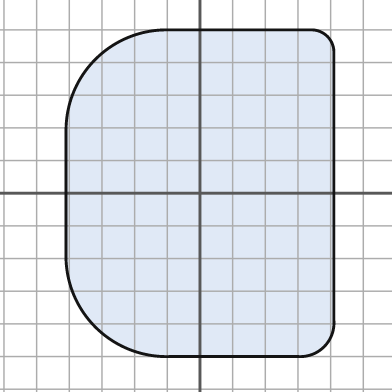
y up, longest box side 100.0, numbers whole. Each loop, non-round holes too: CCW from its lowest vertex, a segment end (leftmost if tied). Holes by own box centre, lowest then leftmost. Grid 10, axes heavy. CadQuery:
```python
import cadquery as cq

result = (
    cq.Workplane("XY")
    .moveTo(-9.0, -50.0)
    .lineTo(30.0, -50.0)
    .threePointArc((38.0, -47.0), (41.0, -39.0))
    .lineTo(41.0, 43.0)
    .threePointArc((39.0, 48.0), (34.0, 50.0))
    .lineTo(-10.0, 50.0)
    .threePointArc((-32.0, 41.0), (-41.0, 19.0))
    .lineTo(-41.0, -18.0)
    .threePointArc((-32.0, -41.0), (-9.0, -50.0))
    .close()
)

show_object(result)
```